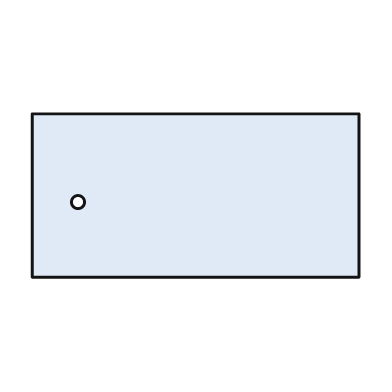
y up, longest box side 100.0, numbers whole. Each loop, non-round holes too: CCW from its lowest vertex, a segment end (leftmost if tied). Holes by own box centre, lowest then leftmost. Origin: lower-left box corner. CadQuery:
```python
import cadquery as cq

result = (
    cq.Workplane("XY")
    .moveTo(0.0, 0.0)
    .lineTo(100.0, 0.0)
    .lineTo(100.0, 50.0)
    .lineTo(0.0, 50.0)
    .close()
    .moveTo(14.0, 23.0)
    .circle(2.0)
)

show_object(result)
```